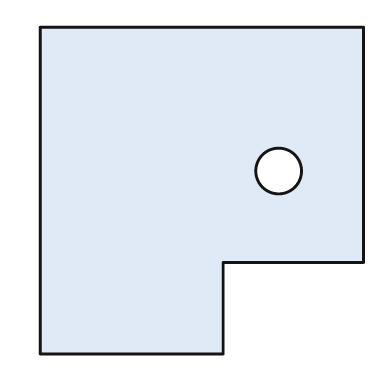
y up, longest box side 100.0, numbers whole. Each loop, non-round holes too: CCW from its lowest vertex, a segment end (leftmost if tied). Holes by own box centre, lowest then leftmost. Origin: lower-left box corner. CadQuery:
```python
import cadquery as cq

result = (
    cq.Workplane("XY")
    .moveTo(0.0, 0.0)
    .lineTo(56.0, 0.0)
    .lineTo(56.0, 28.0)
    .lineTo(99.0, 28.0)
    .lineTo(99.0, 100.0)
    .lineTo(0.0, 100.0)
    .close()
    .moveTo(73.0, 56.0)
    .circle(7.0)
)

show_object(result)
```